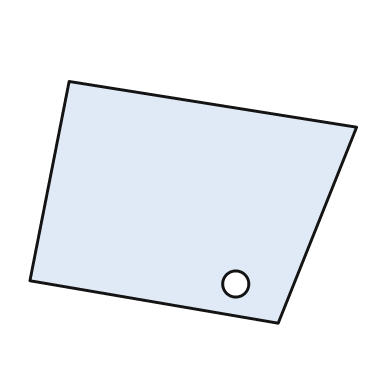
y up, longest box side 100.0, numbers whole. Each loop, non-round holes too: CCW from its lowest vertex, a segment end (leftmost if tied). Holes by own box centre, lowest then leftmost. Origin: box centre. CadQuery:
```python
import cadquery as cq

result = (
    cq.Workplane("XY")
    .moveTo(26.0, -37.0)
    .lineTo(50.0, 23.0)
    .lineTo(-38.0, 37.0)
    .lineTo(-50.0, -24.0)
    .close()
    .moveTo(13.0, -25.0)
    .circle(4.0)
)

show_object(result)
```